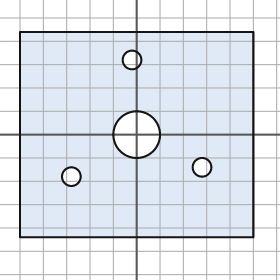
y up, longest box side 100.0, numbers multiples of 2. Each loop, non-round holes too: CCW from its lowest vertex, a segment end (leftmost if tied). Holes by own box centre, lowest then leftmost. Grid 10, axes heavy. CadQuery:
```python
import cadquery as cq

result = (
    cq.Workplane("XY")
    .moveTo(-50.0, -44.0)
    .lineTo(50.0, -44.0)
    .lineTo(50.0, 44.0)
    .lineTo(-50.0, 44.0)
    .close()
    .moveTo(-28.0, -18.0)
    .circle(4.0)
    .moveTo(28.0, -14.0)
    .circle(4.0)
    .moveTo(0.0, 0.0)
    .circle(10.0)
    .moveTo(-2.0, 32.0)
    .circle(4.0)
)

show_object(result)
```